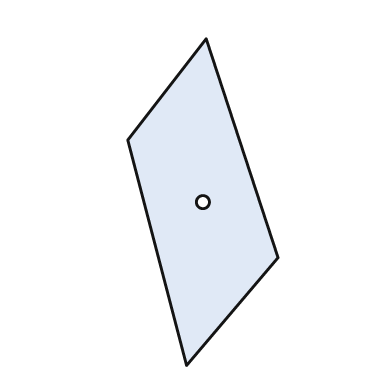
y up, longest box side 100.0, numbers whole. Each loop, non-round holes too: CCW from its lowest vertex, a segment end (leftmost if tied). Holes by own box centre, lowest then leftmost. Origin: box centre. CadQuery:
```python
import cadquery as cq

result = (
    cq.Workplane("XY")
    .moveTo(-5.0, -50.0)
    .lineTo(23.0, -17.0)
    .lineTo(1.0, 50.0)
    .lineTo(-23.0, 19.0)
    .close()
    .moveTo(0.0, 0.0)
    .circle(2.0)
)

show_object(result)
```